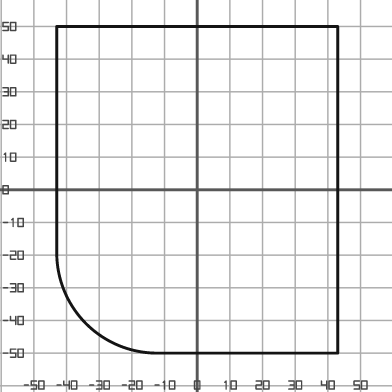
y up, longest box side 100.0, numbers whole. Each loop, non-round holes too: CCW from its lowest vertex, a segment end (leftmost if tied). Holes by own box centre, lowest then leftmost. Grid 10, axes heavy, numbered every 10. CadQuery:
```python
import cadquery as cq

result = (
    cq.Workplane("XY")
    .moveTo(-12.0, -50.0)
    .lineTo(43.0, -50.0)
    .lineTo(43.0, 50.0)
    .lineTo(-43.0, 50.0)
    .lineTo(-43.0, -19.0)
    .threePointArc((-34.0, -41.0), (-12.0, -50.0))
    .close()
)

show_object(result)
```